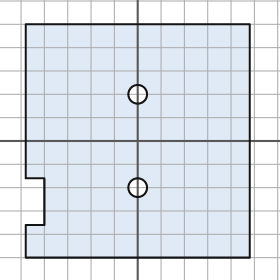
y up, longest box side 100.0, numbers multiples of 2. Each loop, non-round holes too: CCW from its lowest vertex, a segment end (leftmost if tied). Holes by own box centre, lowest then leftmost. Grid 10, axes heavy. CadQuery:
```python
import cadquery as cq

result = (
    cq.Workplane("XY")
    .moveTo(-48.0, -50.0)
    .lineTo(48.0, -50.0)
    .lineTo(48.0, 50.0)
    .lineTo(-48.0, 50.0)
    .lineTo(-48.0, -16.0)
    .lineTo(-40.0, -16.0)
    .lineTo(-40.0, -36.0)
    .lineTo(-48.0, -36.0)
    .close()
    .moveTo(0.0, -20.0)
    .circle(4.0)
    .moveTo(0.0, 20.0)
    .circle(4.0)
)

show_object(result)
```